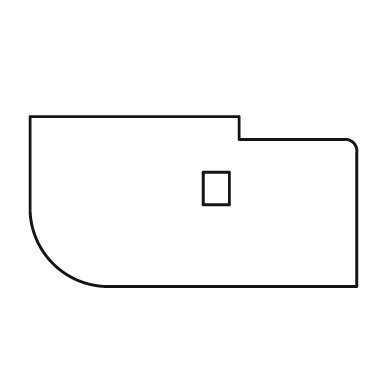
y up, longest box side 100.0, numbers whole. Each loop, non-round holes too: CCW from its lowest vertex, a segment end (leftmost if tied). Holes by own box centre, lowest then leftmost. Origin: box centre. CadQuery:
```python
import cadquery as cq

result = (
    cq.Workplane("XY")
    .moveTo(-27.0, -26.0)
    .lineTo(50.0, -26.0)
    .lineTo(50.0, 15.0)
    .threePointArc((49.0, 18.0), (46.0, 19.0))
    .lineTo(14.0, 19.0)
    .lineTo(14.0, 26.0)
    .lineTo(-50.0, 26.0)
    .lineTo(-50.0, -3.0)
    .threePointArc((-43.0, -19.0), (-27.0, -26.0))
    .close()
    .moveTo(3.0, -1.0)
    .lineTo(11.0, -1.0)
    .lineTo(11.0, 9.0)
    .lineTo(3.0, 9.0)
    .close()
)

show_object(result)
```